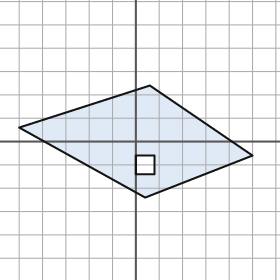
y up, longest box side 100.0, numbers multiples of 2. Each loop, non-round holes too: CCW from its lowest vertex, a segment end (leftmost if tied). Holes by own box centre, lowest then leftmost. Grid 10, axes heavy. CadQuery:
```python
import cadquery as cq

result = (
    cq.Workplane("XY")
    .moveTo(4.0, -24.0)
    .lineTo(50.0, -6.0)
    .lineTo(6.0, 24.0)
    .lineTo(-50.0, 6.0)
    .close()
    .moveTo(0.0, -14.0)
    .lineTo(8.0, -14.0)
    .lineTo(8.0, -6.0)
    .lineTo(0.0, -6.0)
    .close()
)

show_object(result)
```